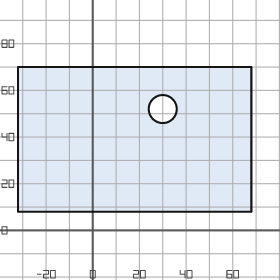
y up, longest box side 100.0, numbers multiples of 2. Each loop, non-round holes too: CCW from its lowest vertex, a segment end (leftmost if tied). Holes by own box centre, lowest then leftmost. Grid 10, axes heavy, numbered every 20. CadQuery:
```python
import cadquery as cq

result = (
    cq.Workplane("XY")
    .moveTo(-32.0, 8.0)
    .lineTo(68.0, 8.0)
    .lineTo(68.0, 70.0)
    .lineTo(-32.0, 70.0)
    .close()
    .moveTo(30.0, 52.0)
    .circle(6.0)
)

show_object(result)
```